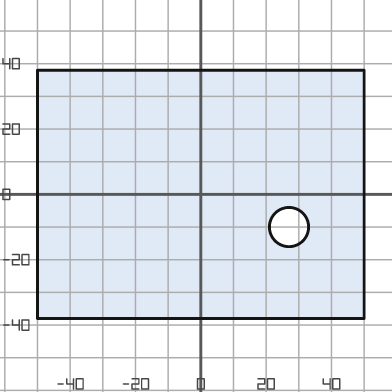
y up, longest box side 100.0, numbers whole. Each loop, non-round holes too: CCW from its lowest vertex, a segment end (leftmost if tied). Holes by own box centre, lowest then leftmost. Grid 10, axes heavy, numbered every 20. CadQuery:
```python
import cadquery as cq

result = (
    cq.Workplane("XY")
    .moveTo(-50.0, -38.0)
    .lineTo(50.0, -38.0)
    .lineTo(50.0, 38.0)
    .lineTo(-50.0, 38.0)
    .close()
    .moveTo(27.0, -10.0)
    .circle(6.0)
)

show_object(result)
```